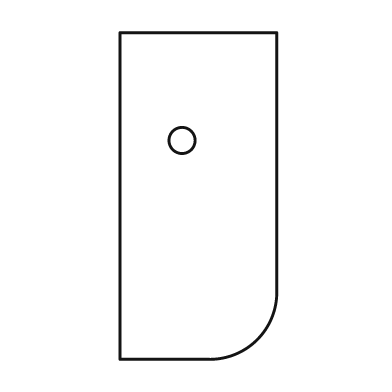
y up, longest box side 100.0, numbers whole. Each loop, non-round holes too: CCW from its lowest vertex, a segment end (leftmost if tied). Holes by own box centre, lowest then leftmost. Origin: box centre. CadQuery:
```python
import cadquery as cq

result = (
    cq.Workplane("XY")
    .moveTo(-24.0, -50.0)
    .lineTo(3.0, -50.0)
    .threePointArc((18.0, -44.0), (24.0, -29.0))
    .lineTo(24.0, 50.0)
    .lineTo(-24.0, 50.0)
    .close()
    .moveTo(-5.0, 17.0)
    .circle(4.0)
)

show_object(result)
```